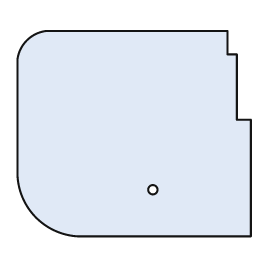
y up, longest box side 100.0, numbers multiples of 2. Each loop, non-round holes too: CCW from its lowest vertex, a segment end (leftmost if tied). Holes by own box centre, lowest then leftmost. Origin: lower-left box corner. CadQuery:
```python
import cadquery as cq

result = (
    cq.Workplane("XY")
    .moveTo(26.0, 0.0)
    .lineTo(100.0, 0.0)
    .lineTo(100.0, 50.0)
    .lineTo(94.0, 50.0)
    .lineTo(94.0, 78.0)
    .lineTo(90.0, 78.0)
    .lineTo(90.0, 88.0)
    .lineTo(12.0, 88.0)
    .threePointArc((4.0, 84.0), (0.0, 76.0))
    .lineTo(0.0, 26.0)
    .threePointArc((8.0, 8.0), (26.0, 0.0))
    .close()
    .moveTo(58.0, 20.0)
    .circle(2.0)
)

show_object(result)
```